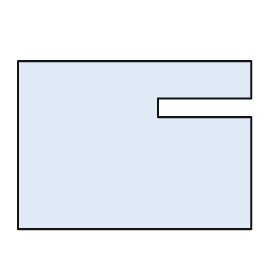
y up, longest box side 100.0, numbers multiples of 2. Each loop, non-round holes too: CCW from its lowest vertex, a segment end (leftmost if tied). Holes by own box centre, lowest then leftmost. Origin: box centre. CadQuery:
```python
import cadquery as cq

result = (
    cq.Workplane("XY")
    .moveTo(-50.0, -36.0)
    .lineTo(50.0, -36.0)
    .lineTo(50.0, 12.0)
    .lineTo(10.0, 12.0)
    .lineTo(10.0, 20.0)
    .lineTo(50.0, 20.0)
    .lineTo(50.0, 36.0)
    .lineTo(-50.0, 36.0)
    .close()
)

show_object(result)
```